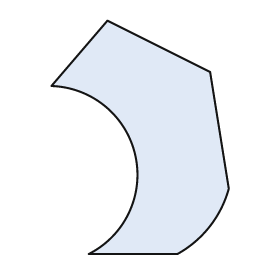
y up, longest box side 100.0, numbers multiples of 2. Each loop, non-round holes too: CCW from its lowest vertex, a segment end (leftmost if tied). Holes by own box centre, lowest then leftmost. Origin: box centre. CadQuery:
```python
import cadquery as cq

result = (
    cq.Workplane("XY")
    .moveTo(-22.0, -50.0)
    .lineTo(16.0, -50.0)
    .threePointArc((30.0, -38.0), (38.0, -22.0))
    .lineTo(30.0, 28.0)
    .lineTo(-14.0, 50.0)
    .lineTo(-38.0, 22.0)
    .threePointArc((-2.0, -8.0), (-22.0, -50.0))
    .close()
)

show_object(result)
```